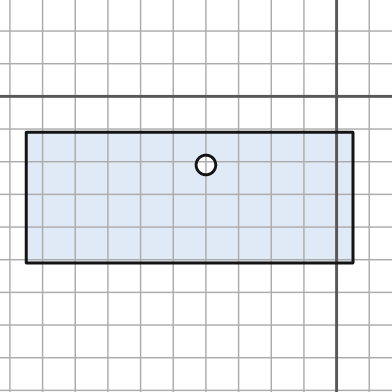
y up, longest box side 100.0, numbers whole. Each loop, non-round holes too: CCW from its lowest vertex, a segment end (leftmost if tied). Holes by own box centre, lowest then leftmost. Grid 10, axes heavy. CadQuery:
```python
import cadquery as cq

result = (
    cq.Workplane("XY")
    .moveTo(-95.0, -51.0)
    .lineTo(5.0, -51.0)
    .lineTo(5.0, -11.0)
    .lineTo(-95.0, -11.0)
    .close()
    .moveTo(-40.0, -21.0)
    .circle(3.0)
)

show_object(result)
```